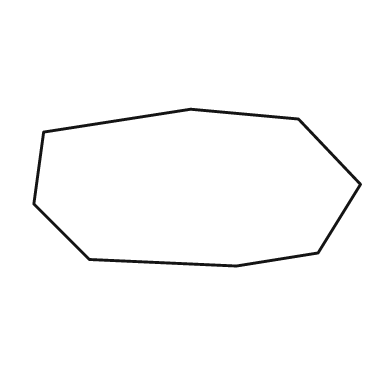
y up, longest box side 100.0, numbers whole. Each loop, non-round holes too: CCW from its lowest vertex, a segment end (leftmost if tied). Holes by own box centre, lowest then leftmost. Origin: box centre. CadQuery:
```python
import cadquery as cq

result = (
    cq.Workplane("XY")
    .moveTo(12.0, -24.0)
    .lineTo(37.0, -20.0)
    .lineTo(50.0, 1.0)
    .lineTo(31.0, 21.0)
    .lineTo(-2.0, 24.0)
    .lineTo(-47.0, 17.0)
    .lineTo(-50.0, -5.0)
    .lineTo(-33.0, -22.0)
    .close()
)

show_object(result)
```